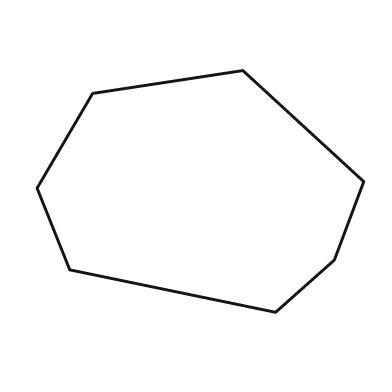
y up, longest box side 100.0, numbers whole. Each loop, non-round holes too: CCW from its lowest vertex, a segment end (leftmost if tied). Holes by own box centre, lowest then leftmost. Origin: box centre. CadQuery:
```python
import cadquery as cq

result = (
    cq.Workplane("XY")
    .moveTo(23.0, -37.0)
    .lineTo(41.0, -21.0)
    .lineTo(50.0, 3.0)
    .lineTo(13.0, 37.0)
    .lineTo(-33.0, 30.0)
    .lineTo(-50.0, 1.0)
    .lineTo(-40.0, -24.0)
    .close()
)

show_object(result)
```